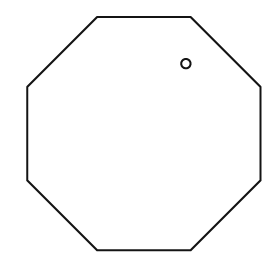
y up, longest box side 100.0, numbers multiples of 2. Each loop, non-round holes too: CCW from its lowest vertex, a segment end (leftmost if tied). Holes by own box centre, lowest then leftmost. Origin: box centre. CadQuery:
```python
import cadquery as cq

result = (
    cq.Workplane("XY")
    .moveTo(-20.0, -50.0)
    .lineTo(20.0, -50.0)
    .lineTo(50.0, -20.0)
    .lineTo(50.0, 20.0)
    .lineTo(20.0, 50.0)
    .lineTo(-20.0, 50.0)
    .lineTo(-50.0, 20.0)
    .lineTo(-50.0, -20.0)
    .close()
    .moveTo(18.0, 30.0)
    .circle(2.0)
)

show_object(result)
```